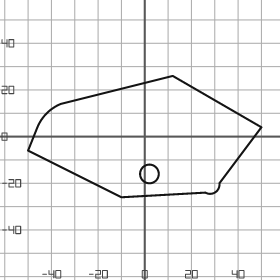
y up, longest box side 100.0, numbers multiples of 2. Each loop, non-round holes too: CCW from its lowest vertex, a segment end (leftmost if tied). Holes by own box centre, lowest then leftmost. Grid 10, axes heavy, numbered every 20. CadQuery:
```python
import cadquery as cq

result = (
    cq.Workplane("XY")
    .moveTo(-10.0, -26.0)
    .lineTo(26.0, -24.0)
    .threePointArc((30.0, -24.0), (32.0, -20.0))
    .lineTo(50.0, 4.0)
    .lineTo(12.0, 26.0)
    .lineTo(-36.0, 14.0)
    .threePointArc((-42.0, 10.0), (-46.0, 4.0))
    .lineTo(-50.0, -6.0)
    .close()
    .moveTo(2.0, -16.0)
    .circle(4.0)
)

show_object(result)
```